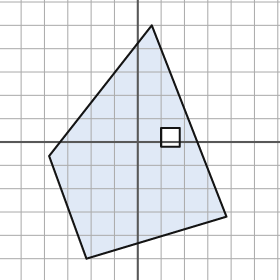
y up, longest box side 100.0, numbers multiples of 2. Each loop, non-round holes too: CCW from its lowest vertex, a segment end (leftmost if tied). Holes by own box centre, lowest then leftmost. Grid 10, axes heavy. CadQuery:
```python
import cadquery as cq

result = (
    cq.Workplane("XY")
    .moveTo(-22.0, -50.0)
    .lineTo(38.0, -32.0)
    .lineTo(6.0, 50.0)
    .lineTo(-38.0, -6.0)
    .close()
    .moveTo(10.0, -2.0)
    .lineTo(18.0, -2.0)
    .lineTo(18.0, 6.0)
    .lineTo(10.0, 6.0)
    .close()
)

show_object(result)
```